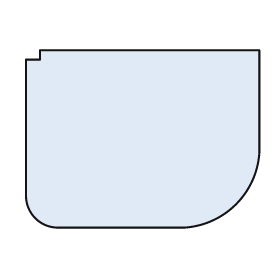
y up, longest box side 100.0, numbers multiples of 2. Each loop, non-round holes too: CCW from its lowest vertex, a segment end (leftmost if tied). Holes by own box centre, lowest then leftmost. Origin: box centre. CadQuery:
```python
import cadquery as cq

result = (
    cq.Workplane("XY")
    .moveTo(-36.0, -38.0)
    .lineTo(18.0, -38.0)
    .threePointArc((40.0, -28.0), (50.0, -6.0))
    .lineTo(50.0, 38.0)
    .lineTo(-44.0, 38.0)
    .lineTo(-44.0, 34.0)
    .lineTo(-50.0, 34.0)
    .lineTo(-50.0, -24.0)
    .threePointArc((-46.0, -34.0), (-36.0, -38.0))
    .close()
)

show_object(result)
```